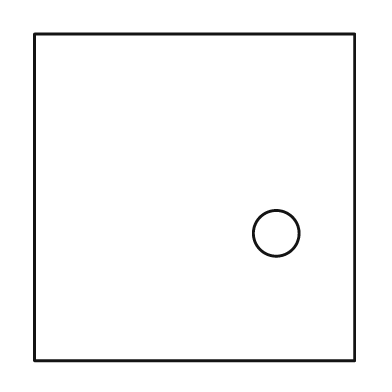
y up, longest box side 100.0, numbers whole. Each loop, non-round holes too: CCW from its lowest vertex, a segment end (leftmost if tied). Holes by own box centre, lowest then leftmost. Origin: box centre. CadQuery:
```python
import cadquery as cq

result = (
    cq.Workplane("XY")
    .moveTo(-49.0, -50.0)
    .lineTo(49.0, -50.0)
    .lineTo(49.0, 50.0)
    .lineTo(-49.0, 50.0)
    .close()
    .moveTo(25.0, -11.0)
    .circle(7.0)
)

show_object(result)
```